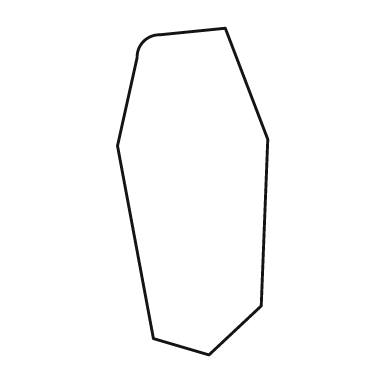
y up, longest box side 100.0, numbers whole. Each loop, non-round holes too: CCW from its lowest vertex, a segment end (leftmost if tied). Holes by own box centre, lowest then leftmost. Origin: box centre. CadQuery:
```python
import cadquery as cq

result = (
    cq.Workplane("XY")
    .moveTo(5.0, -50.0)
    .lineTo(21.0, -35.0)
    .lineTo(23.0, 16.0)
    .lineTo(10.0, 50.0)
    .lineTo(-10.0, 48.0)
    .threePointArc((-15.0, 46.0), (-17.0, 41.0))
    .lineTo(-23.0, 14.0)
    .lineTo(-12.0, -45.0)
    .close()
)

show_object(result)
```